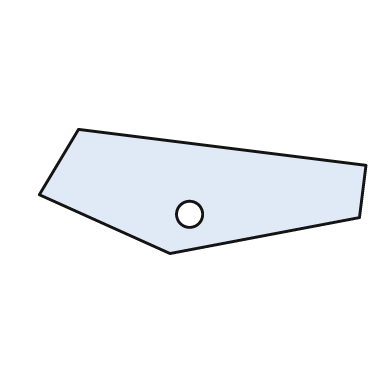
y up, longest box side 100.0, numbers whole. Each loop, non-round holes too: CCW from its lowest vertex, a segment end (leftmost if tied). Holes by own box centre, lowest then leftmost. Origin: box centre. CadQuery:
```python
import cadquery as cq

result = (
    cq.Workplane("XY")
    .moveTo(-10.0, -19.0)
    .lineTo(48.0, -8.0)
    .lineTo(50.0, 8.0)
    .lineTo(-38.0, 19.0)
    .lineTo(-50.0, -1.0)
    .close()
    .moveTo(-4.0, -7.0)
    .circle(4.0)
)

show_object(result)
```